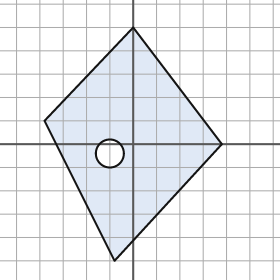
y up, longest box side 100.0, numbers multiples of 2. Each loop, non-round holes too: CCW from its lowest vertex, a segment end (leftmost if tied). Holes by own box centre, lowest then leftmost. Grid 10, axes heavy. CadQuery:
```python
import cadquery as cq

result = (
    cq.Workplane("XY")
    .moveTo(-8.0, -50.0)
    .lineTo(38.0, 0.0)
    .lineTo(0.0, 50.0)
    .lineTo(-38.0, 10.0)
    .close()
    .moveTo(-10.0, -4.0)
    .circle(6.0)
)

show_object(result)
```